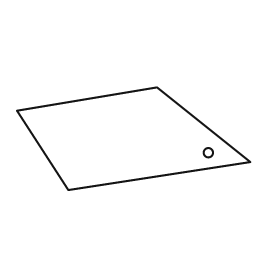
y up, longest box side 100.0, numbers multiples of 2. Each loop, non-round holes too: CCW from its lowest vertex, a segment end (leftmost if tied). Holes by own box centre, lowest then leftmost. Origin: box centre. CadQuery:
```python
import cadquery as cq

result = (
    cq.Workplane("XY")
    .moveTo(-28.0, -22.0)
    .lineTo(50.0, -10.0)
    .lineTo(10.0, 22.0)
    .lineTo(-50.0, 12.0)
    .close()
    .moveTo(32.0, -6.0)
    .circle(2.0)
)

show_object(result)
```